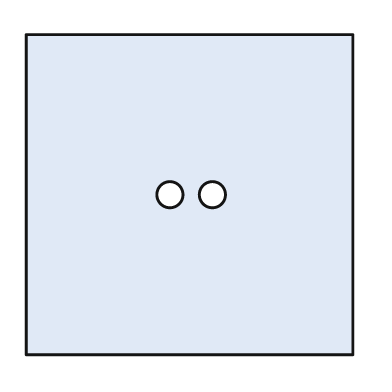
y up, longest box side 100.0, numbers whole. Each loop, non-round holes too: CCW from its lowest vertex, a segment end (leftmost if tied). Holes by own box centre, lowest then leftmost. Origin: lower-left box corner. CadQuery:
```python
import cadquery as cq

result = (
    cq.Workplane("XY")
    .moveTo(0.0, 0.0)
    .lineTo(100.0, 0.0)
    .lineTo(100.0, 98.0)
    .lineTo(0.0, 98.0)
    .close()
    .moveTo(44.0, 49.0)
    .circle(4.0)
    .moveTo(57.0, 49.0)
    .circle(4.0)
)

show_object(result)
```